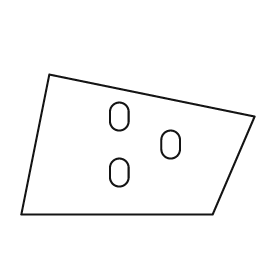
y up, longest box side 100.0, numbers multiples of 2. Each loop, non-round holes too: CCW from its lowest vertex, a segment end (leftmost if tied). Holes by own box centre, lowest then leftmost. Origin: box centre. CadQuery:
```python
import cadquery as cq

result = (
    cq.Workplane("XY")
    .moveTo(-50.0, -30.0)
    .lineTo(32.0, -30.0)
    .lineTo(50.0, 12.0)
    .lineTo(-38.0, 30.0)
    .close()
    .moveTo(-12.0, -14.0)
    .threePointArc((-8.0, -18.0), (-4.0, -14.0))
    .lineTo(-4.0, -10.0)
    .threePointArc((-8.0, -6.0), (-12.0, -10.0))
    .close()
    .moveTo(10.0, -2.0)
    .threePointArc((14.0, -6.0), (18.0, -2.0))
    .lineTo(18.0, 2.0)
    .threePointArc((14.0, 6.0), (10.0, 2.0))
    .close()
    .moveTo(-12.0, 10.0)
    .threePointArc((-8.0, 6.0), (-4.0, 10.0))
    .lineTo(-4.0, 14.0)
    .threePointArc((-8.0, 18.0), (-12.0, 14.0))
    .close()
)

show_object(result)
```